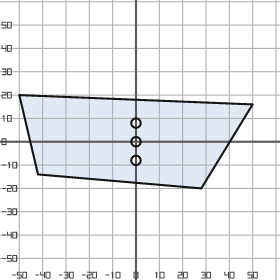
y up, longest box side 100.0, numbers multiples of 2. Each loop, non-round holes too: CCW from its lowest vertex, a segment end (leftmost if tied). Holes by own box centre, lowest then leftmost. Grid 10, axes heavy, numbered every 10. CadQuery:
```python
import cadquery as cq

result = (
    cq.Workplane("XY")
    .moveTo(28.0, -20.0)
    .lineTo(50.0, 16.0)
    .lineTo(-50.0, 20.0)
    .lineTo(-42.0, -14.0)
    .close()
    .moveTo(0.0, -8.0)
    .circle(2.0)
    .moveTo(0.0, 0.0)
    .circle(2.0)
    .moveTo(0.0, 8.0)
    .circle(2.0)
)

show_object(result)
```